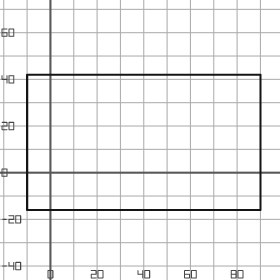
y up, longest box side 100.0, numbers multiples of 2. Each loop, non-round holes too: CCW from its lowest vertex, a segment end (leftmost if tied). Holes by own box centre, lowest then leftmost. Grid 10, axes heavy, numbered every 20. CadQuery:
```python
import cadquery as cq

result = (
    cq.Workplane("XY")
    .moveTo(-10.0, -16.0)
    .lineTo(90.0, -16.0)
    .lineTo(90.0, 42.0)
    .lineTo(-10.0, 42.0)
    .close()
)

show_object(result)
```